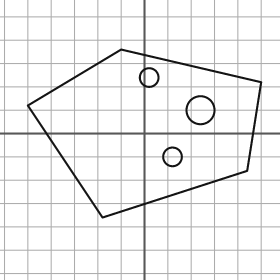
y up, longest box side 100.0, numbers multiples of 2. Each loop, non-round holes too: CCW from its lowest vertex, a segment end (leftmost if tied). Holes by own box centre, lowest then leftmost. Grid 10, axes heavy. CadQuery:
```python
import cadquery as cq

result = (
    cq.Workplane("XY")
    .moveTo(-18.0, -36.0)
    .lineTo(44.0, -16.0)
    .lineTo(50.0, 22.0)
    .lineTo(-10.0, 36.0)
    .lineTo(-50.0, 12.0)
    .close()
    .moveTo(12.0, -10.0)
    .circle(4.0)
    .moveTo(24.0, 10.0)
    .circle(6.0)
    .moveTo(2.0, 24.0)
    .circle(4.0)
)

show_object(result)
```